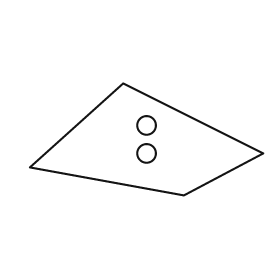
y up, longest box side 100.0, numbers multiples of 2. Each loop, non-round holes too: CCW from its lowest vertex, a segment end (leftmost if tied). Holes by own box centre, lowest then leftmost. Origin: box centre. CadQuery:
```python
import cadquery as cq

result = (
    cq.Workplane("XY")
    .moveTo(16.0, -24.0)
    .lineTo(50.0, -6.0)
    .lineTo(-10.0, 24.0)
    .lineTo(-50.0, -12.0)
    .close()
    .moveTo(0.0, -6.0)
    .circle(4.0)
    .moveTo(0.0, 6.0)
    .circle(4.0)
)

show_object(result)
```